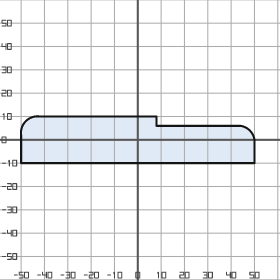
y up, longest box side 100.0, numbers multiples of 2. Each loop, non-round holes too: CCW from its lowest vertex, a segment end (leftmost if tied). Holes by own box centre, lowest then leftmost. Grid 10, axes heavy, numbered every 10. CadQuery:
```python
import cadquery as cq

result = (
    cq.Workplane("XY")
    .moveTo(-50.0, -10.0)
    .lineTo(50.0, -10.0)
    .lineTo(50.0, 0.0)
    .threePointArc((48.0, 4.0), (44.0, 6.0))
    .lineTo(8.0, 6.0)
    .lineTo(8.0, 10.0)
    .lineTo(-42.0, 10.0)
    .threePointArc((-48.0, 8.0), (-50.0, 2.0))
    .close()
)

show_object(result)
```